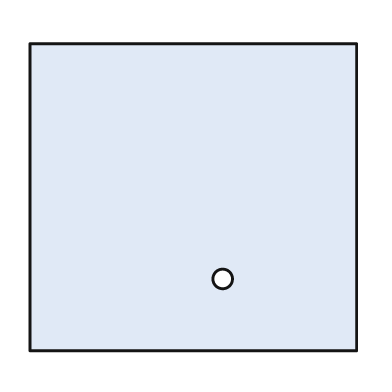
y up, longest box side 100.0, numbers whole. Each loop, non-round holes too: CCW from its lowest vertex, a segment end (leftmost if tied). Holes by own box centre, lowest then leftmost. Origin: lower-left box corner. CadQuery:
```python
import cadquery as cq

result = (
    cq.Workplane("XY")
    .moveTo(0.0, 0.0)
    .lineTo(100.0, 0.0)
    .lineTo(100.0, 94.0)
    .lineTo(0.0, 94.0)
    .close()
    .moveTo(59.0, 22.0)
    .circle(3.0)
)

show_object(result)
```